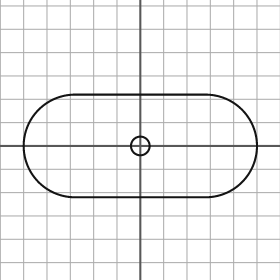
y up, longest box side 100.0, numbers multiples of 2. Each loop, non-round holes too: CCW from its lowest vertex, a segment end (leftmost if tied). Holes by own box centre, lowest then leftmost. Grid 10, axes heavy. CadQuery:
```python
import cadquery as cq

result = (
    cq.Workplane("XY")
    .moveTo(-28.0, -22.0)
    .lineTo(28.0, -22.0)
    .threePointArc((50.0, 0.0), (28.0, 22.0))
    .lineTo(-28.0, 22.0)
    .threePointArc((-50.0, 0.0), (-28.0, -22.0))
    .close()
    .moveTo(0.0, 0.0)
    .circle(4.0)
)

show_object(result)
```